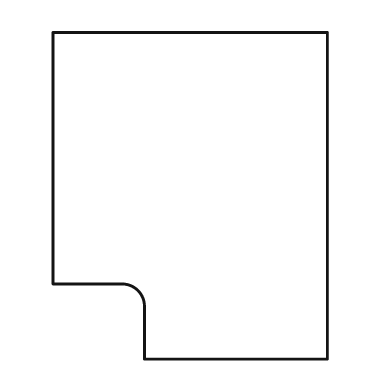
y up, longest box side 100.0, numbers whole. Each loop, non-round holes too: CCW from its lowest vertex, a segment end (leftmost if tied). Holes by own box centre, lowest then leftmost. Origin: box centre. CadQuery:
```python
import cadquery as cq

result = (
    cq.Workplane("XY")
    .moveTo(-14.0, -50.0)
    .lineTo(42.0, -50.0)
    .lineTo(42.0, 50.0)
    .lineTo(-42.0, 50.0)
    .lineTo(-42.0, -27.0)
    .lineTo(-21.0, -27.0)
    .threePointArc((-16.0, -29.0), (-14.0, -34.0))
    .close()
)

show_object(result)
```